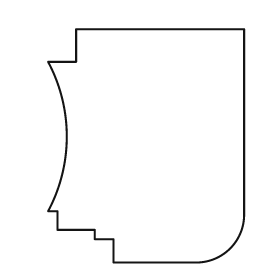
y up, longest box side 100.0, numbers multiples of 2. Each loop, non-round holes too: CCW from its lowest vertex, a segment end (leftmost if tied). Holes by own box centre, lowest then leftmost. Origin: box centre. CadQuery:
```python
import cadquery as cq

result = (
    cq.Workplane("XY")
    .moveTo(-14.0, -50.0)
    .lineTo(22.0, -50.0)
    .threePointArc((36.0, -44.0), (42.0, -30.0))
    .lineTo(42.0, 50.0)
    .lineTo(-30.0, 50.0)
    .lineTo(-30.0, 36.0)
    .lineTo(-42.0, 36.0)
    .threePointArc((-34.0, 4.0), (-42.0, -28.0))
    .lineTo(-38.0, -28.0)
    .lineTo(-38.0, -36.0)
    .lineTo(-22.0, -36.0)
    .lineTo(-22.0, -40.0)
    .lineTo(-14.0, -40.0)
    .close()
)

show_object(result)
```